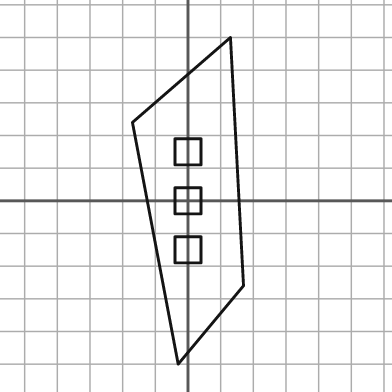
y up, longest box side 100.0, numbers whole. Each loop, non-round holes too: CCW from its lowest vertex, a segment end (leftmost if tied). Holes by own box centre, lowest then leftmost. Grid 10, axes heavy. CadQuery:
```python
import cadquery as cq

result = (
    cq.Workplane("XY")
    .moveTo(-3.0, -50.0)
    .lineTo(17.0, -26.0)
    .lineTo(13.0, 50.0)
    .lineTo(-17.0, 24.0)
    .close()
    .moveTo(-4.0, -19.0)
    .lineTo(4.0, -19.0)
    .lineTo(4.0, -11.0)
    .lineTo(-4.0, -11.0)
    .close()
    .moveTo(-4.0, -4.0)
    .lineTo(4.0, -4.0)
    .lineTo(4.0, 4.0)
    .lineTo(-4.0, 4.0)
    .close()
    .moveTo(-4.0, 11.0)
    .lineTo(4.0, 11.0)
    .lineTo(4.0, 19.0)
    .lineTo(-4.0, 19.0)
    .close()
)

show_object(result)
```